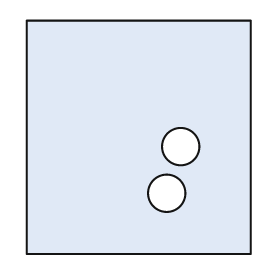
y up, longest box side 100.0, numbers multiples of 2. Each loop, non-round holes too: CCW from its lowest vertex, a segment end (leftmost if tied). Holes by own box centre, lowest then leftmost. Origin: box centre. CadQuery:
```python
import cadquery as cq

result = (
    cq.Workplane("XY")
    .moveTo(-48.0, -50.0)
    .lineTo(48.0, -50.0)
    .lineTo(48.0, 50.0)
    .lineTo(-48.0, 50.0)
    .close()
    .moveTo(12.0, -24.0)
    .circle(8.0)
    .moveTo(18.0, -4.0)
    .circle(8.0)
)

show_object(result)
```